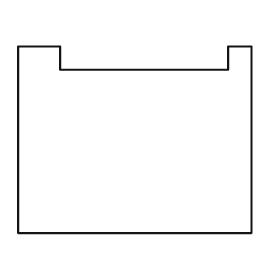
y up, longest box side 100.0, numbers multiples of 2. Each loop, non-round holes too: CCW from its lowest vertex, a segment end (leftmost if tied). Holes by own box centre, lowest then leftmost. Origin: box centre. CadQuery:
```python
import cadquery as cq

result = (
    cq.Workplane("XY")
    .moveTo(-50.0, -40.0)
    .lineTo(50.0, -40.0)
    .lineTo(50.0, 40.0)
    .lineTo(40.0, 40.0)
    .lineTo(40.0, 30.0)
    .lineTo(-32.0, 30.0)
    .lineTo(-32.0, 40.0)
    .lineTo(-50.0, 40.0)
    .close()
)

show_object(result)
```